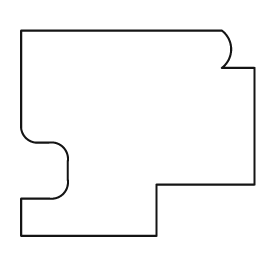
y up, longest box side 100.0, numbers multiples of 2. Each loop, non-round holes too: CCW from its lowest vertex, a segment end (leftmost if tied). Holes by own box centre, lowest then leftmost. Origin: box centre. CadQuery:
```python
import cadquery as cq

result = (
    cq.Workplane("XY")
    .moveTo(-50.0, -44.0)
    .lineTo(8.0, -44.0)
    .lineTo(8.0, -22.0)
    .lineTo(50.0, -22.0)
    .lineTo(50.0, 28.0)
    .lineTo(36.0, 28.0)
    .threePointArc((40.0, 36.0), (36.0, 44.0))
    .lineTo(-50.0, 44.0)
    .lineTo(-50.0, 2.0)
    .threePointArc((-48.0, -2.0), (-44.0, -4.0))
    .lineTo(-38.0, -4.0)
    .threePointArc((-32.0, -6.0), (-30.0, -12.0))
    .lineTo(-30.0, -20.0)
    .threePointArc((-32.0, -26.0), (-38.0, -28.0))
    .lineTo(-50.0, -28.0)
    .close()
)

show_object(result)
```